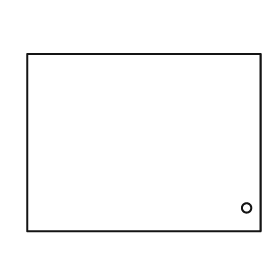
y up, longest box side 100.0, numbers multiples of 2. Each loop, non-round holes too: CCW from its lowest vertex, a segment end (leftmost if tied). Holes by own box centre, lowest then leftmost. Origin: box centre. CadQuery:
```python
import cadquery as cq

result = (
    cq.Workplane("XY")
    .moveTo(-50.0, -38.0)
    .lineTo(50.0, -38.0)
    .lineTo(50.0, 38.0)
    .lineTo(-50.0, 38.0)
    .close()
    .moveTo(44.0, -28.0)
    .circle(2.0)
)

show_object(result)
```